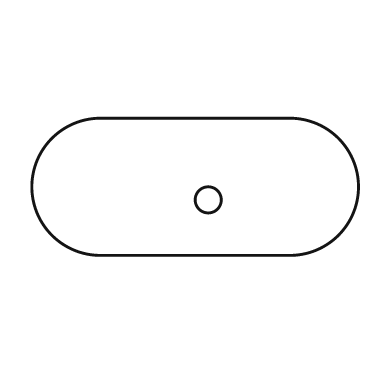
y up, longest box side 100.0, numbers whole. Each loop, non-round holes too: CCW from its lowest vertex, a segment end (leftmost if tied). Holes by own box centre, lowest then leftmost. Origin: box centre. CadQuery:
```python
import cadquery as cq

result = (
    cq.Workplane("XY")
    .moveTo(-29.0, -21.0)
    .lineTo(29.0, -21.0)
    .threePointArc((50.0, 0.0), (29.0, 21.0))
    .lineTo(-29.0, 21.0)
    .threePointArc((-50.0, 0.0), (-29.0, -21.0))
    .close()
    .moveTo(4.0, -4.0)
    .circle(4.0)
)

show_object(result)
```